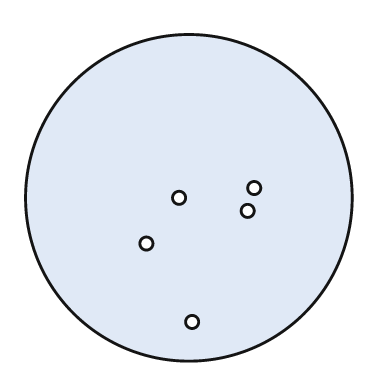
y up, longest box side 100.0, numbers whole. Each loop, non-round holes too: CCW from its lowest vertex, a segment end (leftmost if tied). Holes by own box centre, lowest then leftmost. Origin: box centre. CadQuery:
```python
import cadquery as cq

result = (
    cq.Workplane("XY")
    .moveTo(0.0, 0.0)
    .circle(50.0)
    .moveTo(1.0, -38.0)
    .circle(2.0)
    .moveTo(-13.0, -14.0)
    .circle(2.0)
    .moveTo(18.0, -4.0)
    .circle(2.0)
    .moveTo(-3.0, 0.0)
    .circle(2.0)
    .moveTo(20.0, 3.0)
    .circle(2.0)
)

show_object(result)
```